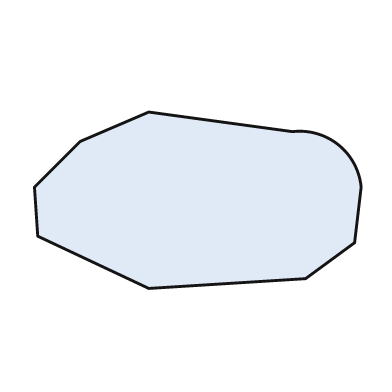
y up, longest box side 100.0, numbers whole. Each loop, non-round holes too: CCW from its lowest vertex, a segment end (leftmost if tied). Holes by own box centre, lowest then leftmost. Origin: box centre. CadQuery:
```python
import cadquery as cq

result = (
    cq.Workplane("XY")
    .moveTo(-15.0, -27.0)
    .lineTo(33.0, -24.0)
    .lineTo(48.0, -13.0)
    .lineTo(50.0, 4.0)
    .threePointArc((43.0, 17.0), (29.0, 21.0))
    .lineTo(-15.0, 27.0)
    .lineTo(-36.0, 18.0)
    .lineTo(-50.0, 4.0)
    .lineTo(-49.0, -11.0)
    .close()
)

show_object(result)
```